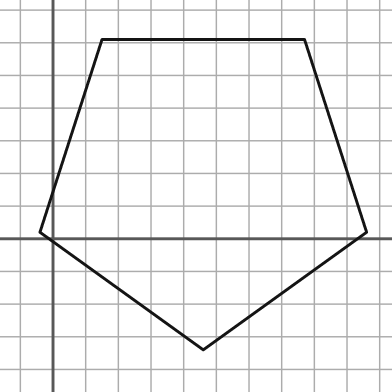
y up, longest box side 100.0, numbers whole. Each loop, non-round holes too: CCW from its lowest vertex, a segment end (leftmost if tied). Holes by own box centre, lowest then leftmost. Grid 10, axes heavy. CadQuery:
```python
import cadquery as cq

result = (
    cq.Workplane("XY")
    .moveTo(46.0, -34.0)
    .lineTo(96.0, 2.0)
    .lineTo(77.0, 61.0)
    .lineTo(15.0, 61.0)
    .lineTo(-4.0, 2.0)
    .close()
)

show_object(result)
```